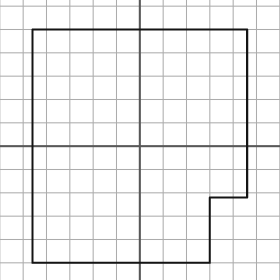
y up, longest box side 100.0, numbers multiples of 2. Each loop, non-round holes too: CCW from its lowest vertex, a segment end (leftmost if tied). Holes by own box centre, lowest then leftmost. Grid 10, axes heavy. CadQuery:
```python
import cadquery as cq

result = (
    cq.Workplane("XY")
    .moveTo(-46.0, -50.0)
    .lineTo(30.0, -50.0)
    .lineTo(30.0, -22.0)
    .lineTo(46.0, -22.0)
    .lineTo(46.0, 50.0)
    .lineTo(-46.0, 50.0)
    .close()
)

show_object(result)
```